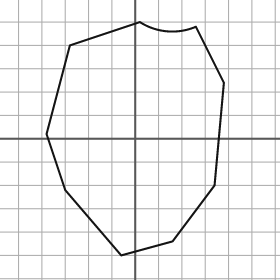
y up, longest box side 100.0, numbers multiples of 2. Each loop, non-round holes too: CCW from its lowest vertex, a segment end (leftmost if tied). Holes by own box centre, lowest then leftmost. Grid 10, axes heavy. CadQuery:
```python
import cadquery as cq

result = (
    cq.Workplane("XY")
    .moveTo(-6.0, -50.0)
    .lineTo(16.0, -44.0)
    .lineTo(34.0, -20.0)
    .lineTo(38.0, 24.0)
    .lineTo(26.0, 48.0)
    .threePointArc((14.0, 46.0), (2.0, 50.0))
    .lineTo(-28.0, 40.0)
    .lineTo(-38.0, 2.0)
    .lineTo(-30.0, -22.0)
    .close()
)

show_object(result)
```